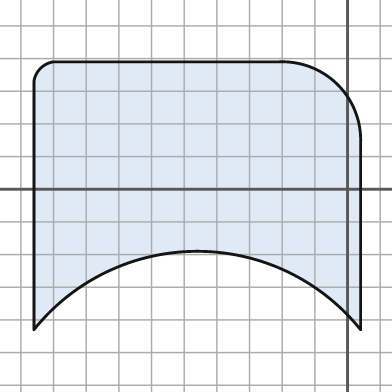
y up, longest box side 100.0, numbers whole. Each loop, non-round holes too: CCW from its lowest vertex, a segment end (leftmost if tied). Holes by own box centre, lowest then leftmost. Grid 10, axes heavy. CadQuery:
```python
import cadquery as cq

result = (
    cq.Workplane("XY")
    .moveTo(-96.0, -43.0)
    .threePointArc((-46.0, -19.0), (4.0, -43.0))
    .lineTo(4.0, 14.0)
    .threePointArc((-3.0, 32.0), (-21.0, 39.0))
    .lineTo(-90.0, 39.0)
    .threePointArc((-94.0, 37.0), (-96.0, 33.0))
    .close()
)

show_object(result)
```